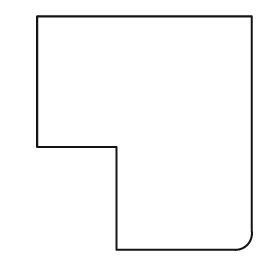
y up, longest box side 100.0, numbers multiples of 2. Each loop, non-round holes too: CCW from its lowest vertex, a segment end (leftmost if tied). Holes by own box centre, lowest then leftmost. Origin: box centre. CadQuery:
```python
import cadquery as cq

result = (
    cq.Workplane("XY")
    .moveTo(-12.0, -50.0)
    .lineTo(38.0, -50.0)
    .threePointArc((44.0, -48.0), (46.0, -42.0))
    .lineTo(46.0, 50.0)
    .lineTo(-46.0, 50.0)
    .lineTo(-46.0, -6.0)
    .lineTo(-12.0, -6.0)
    .close()
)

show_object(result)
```